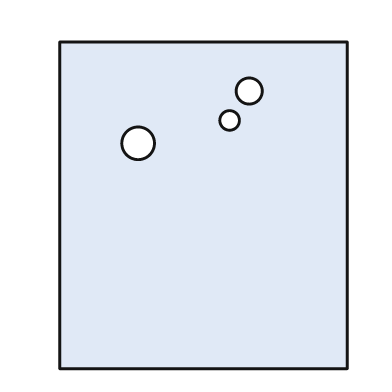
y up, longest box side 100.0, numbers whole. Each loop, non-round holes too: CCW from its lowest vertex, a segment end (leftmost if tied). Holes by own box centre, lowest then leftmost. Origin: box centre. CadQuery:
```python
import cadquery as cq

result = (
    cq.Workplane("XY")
    .moveTo(-44.0, -50.0)
    .lineTo(44.0, -50.0)
    .lineTo(44.0, 50.0)
    .lineTo(-44.0, 50.0)
    .close()
    .moveTo(-20.0, 19.0)
    .circle(5.0)
    .moveTo(8.0, 26.0)
    .circle(3.0)
    .moveTo(14.0, 35.0)
    .circle(4.0)
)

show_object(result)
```